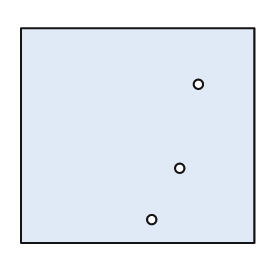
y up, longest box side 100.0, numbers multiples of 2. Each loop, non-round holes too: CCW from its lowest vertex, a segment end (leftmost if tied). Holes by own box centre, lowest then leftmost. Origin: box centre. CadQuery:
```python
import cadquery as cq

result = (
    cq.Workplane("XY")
    .moveTo(-50.0, -46.0)
    .lineTo(50.0, -46.0)
    .lineTo(50.0, 46.0)
    .lineTo(-50.0, 46.0)
    .close()
    .moveTo(6.0, -36.0)
    .circle(2.0)
    .moveTo(18.0, -14.0)
    .circle(2.0)
    .moveTo(26.0, 22.0)
    .circle(2.0)
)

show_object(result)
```